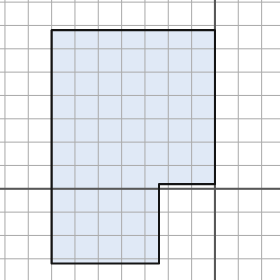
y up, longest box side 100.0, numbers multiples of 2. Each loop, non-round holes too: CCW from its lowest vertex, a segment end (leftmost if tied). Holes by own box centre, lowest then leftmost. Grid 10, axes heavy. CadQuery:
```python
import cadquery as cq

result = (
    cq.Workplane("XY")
    .moveTo(-70.0, -32.0)
    .lineTo(-24.0, -32.0)
    .lineTo(-24.0, 2.0)
    .lineTo(0.0, 2.0)
    .lineTo(0.0, 68.0)
    .lineTo(-70.0, 68.0)
    .close()
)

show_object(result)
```